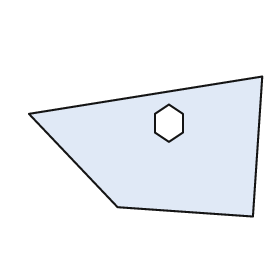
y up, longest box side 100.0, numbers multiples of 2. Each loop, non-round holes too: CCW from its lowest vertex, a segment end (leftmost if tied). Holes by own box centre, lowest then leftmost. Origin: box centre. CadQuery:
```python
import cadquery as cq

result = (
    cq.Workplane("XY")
    .moveTo(46.0, -30.0)
    .lineTo(50.0, 30.0)
    .lineTo(-50.0, 14.0)
    .lineTo(-12.0, -26.0)
    .close()
    .moveTo(10.0, 2.0)
    .lineTo(16.0, 6.0)
    .lineTo(16.0, 14.0)
    .lineTo(10.0, 18.0)
    .lineTo(4.0, 14.0)
    .lineTo(4.0, 6.0)
    .close()
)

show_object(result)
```